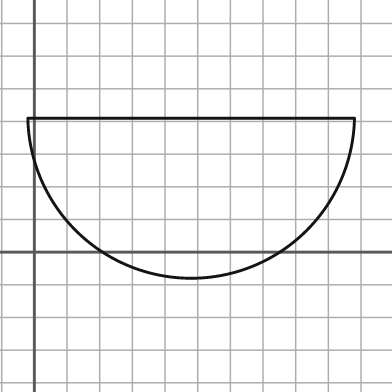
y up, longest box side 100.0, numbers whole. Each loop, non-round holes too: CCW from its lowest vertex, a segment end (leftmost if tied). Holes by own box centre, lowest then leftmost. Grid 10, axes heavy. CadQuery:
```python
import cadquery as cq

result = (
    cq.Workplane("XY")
    .moveTo(-2.0, 41.0)
    .threePointArc((48.0, -8.0), (98.0, 41.0))
    .close()
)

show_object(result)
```